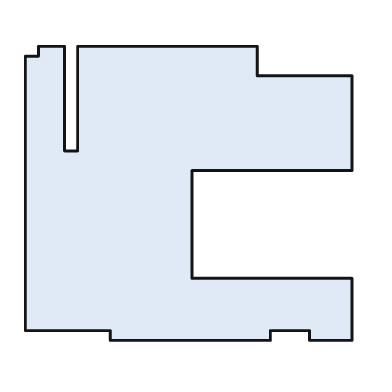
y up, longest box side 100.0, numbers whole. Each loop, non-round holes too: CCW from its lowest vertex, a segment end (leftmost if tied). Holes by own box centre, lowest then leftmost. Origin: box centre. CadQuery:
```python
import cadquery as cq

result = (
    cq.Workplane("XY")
    .moveTo(-24.0, -45.0)
    .lineTo(25.0, -45.0)
    .lineTo(25.0, -42.0)
    .lineTo(37.0, -42.0)
    .lineTo(37.0, -45.0)
    .lineTo(50.0, -45.0)
    .lineTo(50.0, -26.0)
    .lineTo(1.0, -26.0)
    .lineTo(1.0, 7.0)
    .lineTo(50.0, 7.0)
    .lineTo(50.0, 36.0)
    .lineTo(21.0, 36.0)
    .lineTo(21.0, 45.0)
    .lineTo(-34.0, 45.0)
    .lineTo(-34.0, 13.0)
    .lineTo(-38.0, 13.0)
    .lineTo(-38.0, 45.0)
    .lineTo(-46.0, 45.0)
    .lineTo(-46.0, 42.0)
    .lineTo(-50.0, 42.0)
    .lineTo(-50.0, -42.0)
    .lineTo(-24.0, -42.0)
    .close()
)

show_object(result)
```